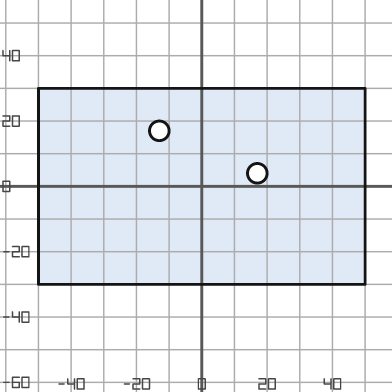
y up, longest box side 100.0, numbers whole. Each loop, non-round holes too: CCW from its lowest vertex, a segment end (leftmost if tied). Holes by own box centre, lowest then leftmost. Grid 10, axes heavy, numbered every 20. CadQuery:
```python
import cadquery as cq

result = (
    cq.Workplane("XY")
    .moveTo(-50.0, -30.0)
    .lineTo(50.0, -30.0)
    .lineTo(50.0, 30.0)
    .lineTo(-50.0, 30.0)
    .close()
    .moveTo(17.0, 4.0)
    .circle(3.0)
    .moveTo(-13.0, 17.0)
    .circle(3.0)
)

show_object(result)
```